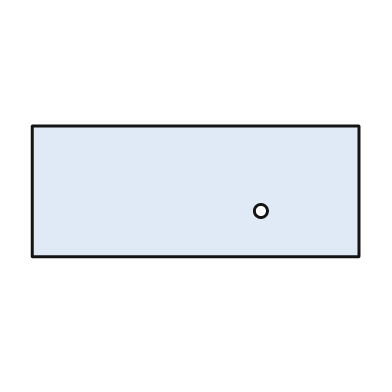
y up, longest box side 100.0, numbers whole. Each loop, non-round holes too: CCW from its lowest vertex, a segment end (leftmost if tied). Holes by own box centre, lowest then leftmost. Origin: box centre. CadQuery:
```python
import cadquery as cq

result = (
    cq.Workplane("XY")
    .moveTo(-50.0, -20.0)
    .lineTo(50.0, -20.0)
    .lineTo(50.0, 20.0)
    .lineTo(-50.0, 20.0)
    .close()
    .moveTo(20.0, -6.0)
    .circle(2.0)
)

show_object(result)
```